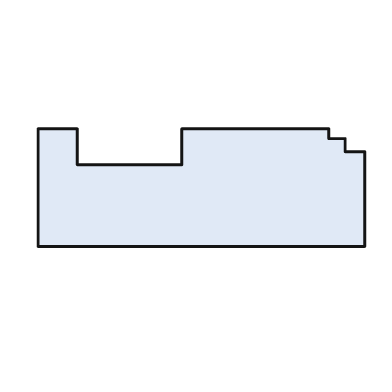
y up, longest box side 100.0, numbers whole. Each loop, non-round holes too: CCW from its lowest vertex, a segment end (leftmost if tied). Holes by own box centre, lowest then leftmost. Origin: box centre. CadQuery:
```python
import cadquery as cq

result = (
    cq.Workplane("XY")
    .moveTo(-50.0, -18.0)
    .lineTo(50.0, -18.0)
    .lineTo(50.0, 11.0)
    .lineTo(44.0, 11.0)
    .lineTo(44.0, 15.0)
    .lineTo(39.0, 15.0)
    .lineTo(39.0, 18.0)
    .lineTo(-6.0, 18.0)
    .lineTo(-6.0, 7.0)
    .lineTo(-38.0, 7.0)
    .lineTo(-38.0, 18.0)
    .lineTo(-50.0, 18.0)
    .close()
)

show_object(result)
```